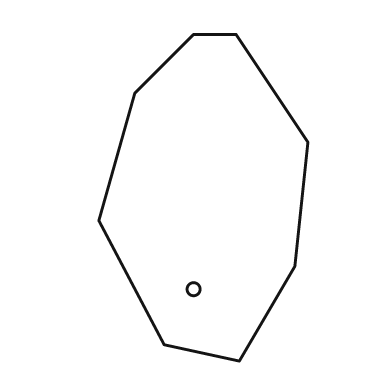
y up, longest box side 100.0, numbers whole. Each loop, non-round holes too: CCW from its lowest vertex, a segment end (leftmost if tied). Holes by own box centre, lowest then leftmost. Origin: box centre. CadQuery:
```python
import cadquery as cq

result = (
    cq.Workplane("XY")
    .moveTo(11.0, -50.0)
    .lineTo(28.0, -21.0)
    .lineTo(32.0, 17.0)
    .lineTo(10.0, 50.0)
    .lineTo(-3.0, 50.0)
    .lineTo(-21.0, 32.0)
    .lineTo(-32.0, -7.0)
    .lineTo(-12.0, -45.0)
    .close()
    .moveTo(-3.0, -28.0)
    .circle(2.0)
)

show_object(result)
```